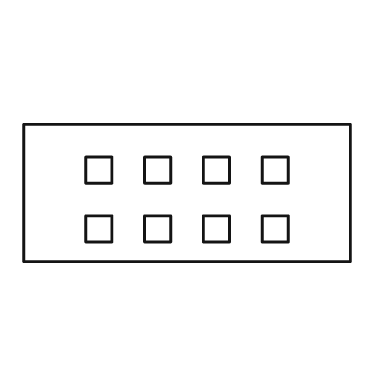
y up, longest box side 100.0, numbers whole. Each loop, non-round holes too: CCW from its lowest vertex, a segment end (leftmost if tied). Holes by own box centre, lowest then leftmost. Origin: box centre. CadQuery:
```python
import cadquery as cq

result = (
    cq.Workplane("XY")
    .moveTo(-50.0, -21.0)
    .lineTo(50.0, -21.0)
    .lineTo(50.0, 21.0)
    .lineTo(-50.0, 21.0)
    .close()
    .moveTo(-31.0, -15.0)
    .lineTo(-23.0, -15.0)
    .lineTo(-23.0, -7.0)
    .lineTo(-31.0, -7.0)
    .close()
    .moveTo(-13.0, -15.0)
    .lineTo(-5.0, -15.0)
    .lineTo(-5.0, -7.0)
    .lineTo(-13.0, -7.0)
    .close()
    .moveTo(5.0, -15.0)
    .lineTo(13.0, -15.0)
    .lineTo(13.0, -7.0)
    .lineTo(5.0, -7.0)
    .close()
    .moveTo(23.0, -15.0)
    .lineTo(31.0, -15.0)
    .lineTo(31.0, -7.0)
    .lineTo(23.0, -7.0)
    .close()
    .moveTo(-31.0, 3.0)
    .lineTo(-23.0, 3.0)
    .lineTo(-23.0, 11.0)
    .lineTo(-31.0, 11.0)
    .close()
    .moveTo(-13.0, 3.0)
    .lineTo(-5.0, 3.0)
    .lineTo(-5.0, 11.0)
    .lineTo(-13.0, 11.0)
    .close()
    .moveTo(5.0, 3.0)
    .lineTo(13.0, 3.0)
    .lineTo(13.0, 11.0)
    .lineTo(5.0, 11.0)
    .close()
    .moveTo(23.0, 3.0)
    .lineTo(31.0, 3.0)
    .lineTo(31.0, 11.0)
    .lineTo(23.0, 11.0)
    .close()
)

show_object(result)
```